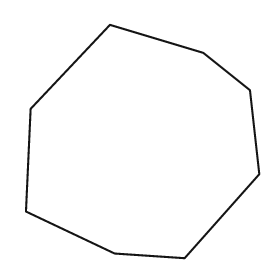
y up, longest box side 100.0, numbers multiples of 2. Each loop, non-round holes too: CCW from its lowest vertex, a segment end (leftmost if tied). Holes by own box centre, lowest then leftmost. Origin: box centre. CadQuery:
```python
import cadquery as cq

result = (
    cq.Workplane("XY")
    .moveTo(18.0, -50.0)
    .lineTo(50.0, -14.0)
    .lineTo(46.0, 22.0)
    .lineTo(26.0, 38.0)
    .lineTo(-14.0, 50.0)
    .lineTo(-48.0, 14.0)
    .lineTo(-50.0, -30.0)
    .lineTo(-12.0, -48.0)
    .close()
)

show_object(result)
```